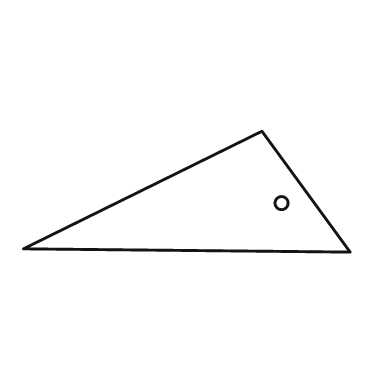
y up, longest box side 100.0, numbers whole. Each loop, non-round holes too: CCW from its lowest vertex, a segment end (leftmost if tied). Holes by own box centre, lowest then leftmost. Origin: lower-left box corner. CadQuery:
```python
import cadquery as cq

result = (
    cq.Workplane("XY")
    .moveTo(100.0, 0.0)
    .lineTo(73.0, 37.0)
    .lineTo(0.0, 1.0)
    .close()
    .moveTo(79.0, 15.0)
    .circle(2.0)
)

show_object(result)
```